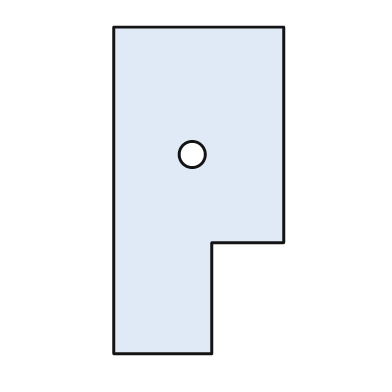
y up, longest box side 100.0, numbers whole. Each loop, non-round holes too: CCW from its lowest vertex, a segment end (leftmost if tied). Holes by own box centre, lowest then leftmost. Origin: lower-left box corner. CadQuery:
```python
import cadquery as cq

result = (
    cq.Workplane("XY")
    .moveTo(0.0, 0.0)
    .lineTo(30.0, 0.0)
    .lineTo(30.0, 34.0)
    .lineTo(52.0, 34.0)
    .lineTo(52.0, 100.0)
    .lineTo(0.0, 100.0)
    .close()
    .moveTo(24.0, 61.0)
    .circle(4.0)
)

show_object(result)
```